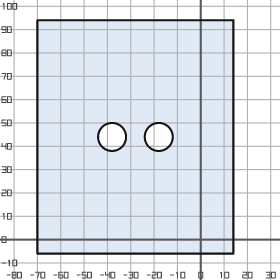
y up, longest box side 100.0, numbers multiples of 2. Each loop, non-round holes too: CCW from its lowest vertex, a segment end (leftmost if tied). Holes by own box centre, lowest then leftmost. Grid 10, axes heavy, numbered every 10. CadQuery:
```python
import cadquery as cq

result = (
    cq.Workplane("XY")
    .moveTo(-70.0, -6.0)
    .lineTo(14.0, -6.0)
    .lineTo(14.0, 94.0)
    .lineTo(-70.0, 94.0)
    .close()
    .moveTo(-38.0, 44.0)
    .circle(6.0)
    .moveTo(-18.0, 44.0)
    .circle(6.0)
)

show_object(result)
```